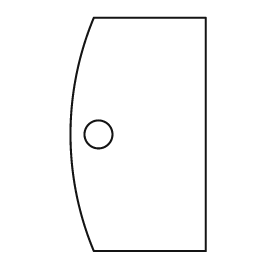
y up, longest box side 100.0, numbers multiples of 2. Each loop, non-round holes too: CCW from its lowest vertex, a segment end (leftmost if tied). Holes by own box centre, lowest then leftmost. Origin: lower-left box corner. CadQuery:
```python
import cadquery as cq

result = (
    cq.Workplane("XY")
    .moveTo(10.0, 0.0)
    .lineTo(58.0, 0.0)
    .lineTo(58.0, 100.0)
    .lineTo(10.0, 100.0)
    .threePointArc((0.0, 50.0), (10.0, 0.0))
    .close()
    .moveTo(12.0, 50.0)
    .circle(6.0)
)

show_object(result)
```